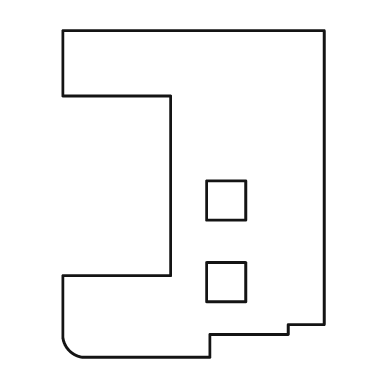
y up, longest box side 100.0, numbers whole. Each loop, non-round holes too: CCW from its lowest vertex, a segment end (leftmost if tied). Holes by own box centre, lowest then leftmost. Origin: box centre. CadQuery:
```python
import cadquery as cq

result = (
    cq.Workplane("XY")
    .moveTo(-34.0, -50.0)
    .lineTo(5.0, -50.0)
    .lineTo(5.0, -43.0)
    .lineTo(29.0, -43.0)
    .lineTo(29.0, -40.0)
    .lineTo(40.0, -40.0)
    .lineTo(40.0, 50.0)
    .lineTo(-40.0, 50.0)
    .lineTo(-40.0, 30.0)
    .lineTo(-7.0, 30.0)
    .lineTo(-7.0, -25.0)
    .lineTo(-40.0, -25.0)
    .lineTo(-40.0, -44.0)
    .threePointArc((-38.0, -48.0), (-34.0, -50.0))
    .close()
    .moveTo(4.0, -33.0)
    .lineTo(16.0, -33.0)
    .lineTo(16.0, -21.0)
    .lineTo(4.0, -21.0)
    .close()
    .moveTo(4.0, -8.0)
    .lineTo(16.0, -8.0)
    .lineTo(16.0, 4.0)
    .lineTo(4.0, 4.0)
    .close()
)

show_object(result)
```